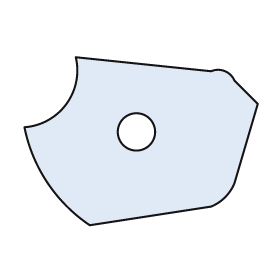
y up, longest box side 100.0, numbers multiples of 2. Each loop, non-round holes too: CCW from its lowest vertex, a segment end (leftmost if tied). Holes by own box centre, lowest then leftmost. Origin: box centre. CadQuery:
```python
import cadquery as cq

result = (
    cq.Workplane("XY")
    .moveTo(-22.0, -36.0)
    .lineTo(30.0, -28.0)
    .threePointArc((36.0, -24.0), (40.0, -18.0))
    .lineTo(50.0, 16.0)
    .lineTo(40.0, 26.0)
    .threePointArc((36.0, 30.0), (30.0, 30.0))
    .lineTo(-28.0, 36.0)
    .threePointArc((-32.0, 16.0), (-50.0, 6.0))
    .threePointArc((-40.0, -18.0), (-22.0, -36.0))
    .close()
    .moveTo(-2.0, 4.0)
    .circle(8.0)
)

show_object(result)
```